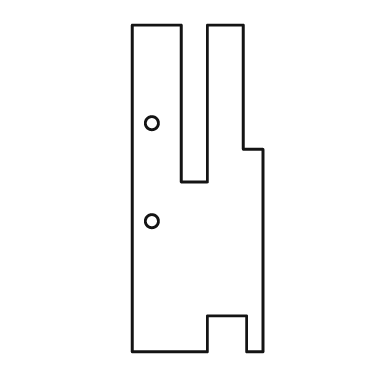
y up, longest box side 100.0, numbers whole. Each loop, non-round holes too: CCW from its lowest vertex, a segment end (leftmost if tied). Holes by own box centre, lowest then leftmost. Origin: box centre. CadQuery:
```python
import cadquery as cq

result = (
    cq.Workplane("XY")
    .moveTo(-20.0, -50.0)
    .lineTo(3.0, -50.0)
    .lineTo(3.0, -39.0)
    .lineTo(15.0, -39.0)
    .lineTo(15.0, -50.0)
    .lineTo(20.0, -50.0)
    .lineTo(20.0, 12.0)
    .lineTo(14.0, 12.0)
    .lineTo(14.0, 50.0)
    .lineTo(3.0, 50.0)
    .lineTo(3.0, 2.0)
    .lineTo(-5.0, 2.0)
    .lineTo(-5.0, 50.0)
    .lineTo(-20.0, 50.0)
    .close()
    .moveTo(-14.0, -10.0)
    .circle(2.0)
    .moveTo(-14.0, 20.0)
    .circle(2.0)
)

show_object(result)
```